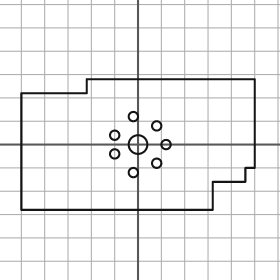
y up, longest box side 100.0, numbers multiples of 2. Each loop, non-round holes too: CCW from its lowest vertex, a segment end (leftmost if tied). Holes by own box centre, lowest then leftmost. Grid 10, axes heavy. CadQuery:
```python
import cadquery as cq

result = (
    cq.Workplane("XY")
    .moveTo(-50.0, -28.0)
    .lineTo(32.0, -28.0)
    .lineTo(32.0, -16.0)
    .lineTo(46.0, -16.0)
    .lineTo(46.0, -10.0)
    .lineTo(50.0, -10.0)
    .lineTo(50.0, 28.0)
    .lineTo(-22.0, 28.0)
    .lineTo(-22.0, 22.0)
    .lineTo(-50.0, 22.0)
    .close()
    .moveTo(-2.0, -12.0)
    .circle(2.0)
    .moveTo(8.0, -8.0)
    .circle(2.0)
    .moveTo(-10.0, -4.0)
    .circle(2.0)
    .moveTo(0.0, 0.0)
    .circle(4.0)
    .moveTo(12.0, 0.0)
    .circle(2.0)
    .moveTo(-10.0, 4.0)
    .circle(2.0)
    .moveTo(8.0, 8.0)
    .circle(2.0)
    .moveTo(-2.0, 12.0)
    .circle(2.0)
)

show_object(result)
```